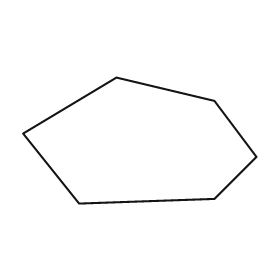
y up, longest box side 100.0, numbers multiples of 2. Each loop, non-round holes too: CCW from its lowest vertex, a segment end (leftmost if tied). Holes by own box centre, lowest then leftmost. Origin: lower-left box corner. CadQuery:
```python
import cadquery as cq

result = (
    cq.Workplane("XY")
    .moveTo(24.0, 0.0)
    .lineTo(82.0, 2.0)
    .lineTo(100.0, 20.0)
    .lineTo(82.0, 44.0)
    .lineTo(40.0, 54.0)
    .lineTo(0.0, 30.0)
    .close()
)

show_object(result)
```